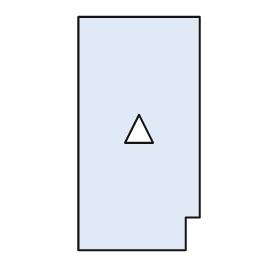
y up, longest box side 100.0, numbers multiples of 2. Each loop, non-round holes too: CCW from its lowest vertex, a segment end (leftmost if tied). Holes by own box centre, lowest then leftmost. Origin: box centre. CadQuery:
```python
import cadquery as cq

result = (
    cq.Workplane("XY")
    .moveTo(-26.0, -50.0)
    .lineTo(20.0, -50.0)
    .lineTo(20.0, -36.0)
    .lineTo(26.0, -36.0)
    .lineTo(26.0, 50.0)
    .lineTo(-26.0, 50.0)
    .close()
    .moveTo(-6.0, -4.0)
    .lineTo(6.0, -4.0)
    .lineTo(0.0, 8.0)
    .close()
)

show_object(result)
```